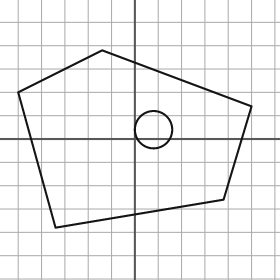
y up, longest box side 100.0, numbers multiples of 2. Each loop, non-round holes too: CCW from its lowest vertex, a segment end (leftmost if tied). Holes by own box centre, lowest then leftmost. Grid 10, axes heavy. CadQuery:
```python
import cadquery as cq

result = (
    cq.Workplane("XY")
    .moveTo(-34.0, -38.0)
    .lineTo(38.0, -26.0)
    .lineTo(50.0, 14.0)
    .lineTo(-14.0, 38.0)
    .lineTo(-50.0, 20.0)
    .close()
    .moveTo(8.0, 4.0)
    .circle(8.0)
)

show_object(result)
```